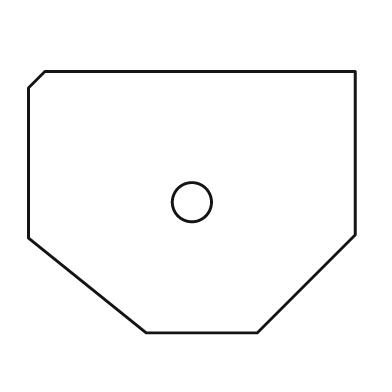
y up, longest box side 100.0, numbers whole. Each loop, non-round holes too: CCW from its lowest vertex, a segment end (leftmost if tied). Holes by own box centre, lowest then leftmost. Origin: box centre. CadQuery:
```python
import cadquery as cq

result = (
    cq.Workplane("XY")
    .moveTo(-14.0, -40.0)
    .lineTo(20.0, -40.0)
    .lineTo(50.0, -10.0)
    .lineTo(50.0, 40.0)
    .lineTo(-45.0, 40.0)
    .lineTo(-50.0, 35.0)
    .lineTo(-50.0, -11.0)
    .close()
    .moveTo(0.0, 0.0)
    .circle(6.0)
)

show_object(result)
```